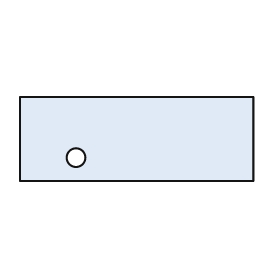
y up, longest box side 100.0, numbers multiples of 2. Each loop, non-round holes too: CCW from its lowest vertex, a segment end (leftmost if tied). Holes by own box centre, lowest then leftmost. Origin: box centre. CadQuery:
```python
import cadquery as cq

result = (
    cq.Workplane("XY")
    .moveTo(-50.0, -18.0)
    .lineTo(50.0, -18.0)
    .lineTo(50.0, 18.0)
    .lineTo(-50.0, 18.0)
    .close()
    .moveTo(-26.0, -8.0)
    .circle(4.0)
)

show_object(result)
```